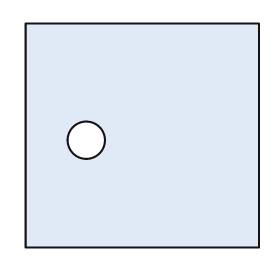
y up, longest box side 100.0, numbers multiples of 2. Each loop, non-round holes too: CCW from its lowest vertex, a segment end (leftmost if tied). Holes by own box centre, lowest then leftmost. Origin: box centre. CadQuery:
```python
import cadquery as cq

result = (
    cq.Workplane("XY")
    .moveTo(-50.0, -48.0)
    .lineTo(50.0, -48.0)
    .lineTo(50.0, 48.0)
    .lineTo(-50.0, 48.0)
    .close()
    .moveTo(-24.0, -2.0)
    .circle(8.0)
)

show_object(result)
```